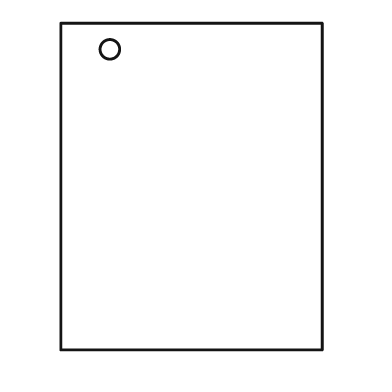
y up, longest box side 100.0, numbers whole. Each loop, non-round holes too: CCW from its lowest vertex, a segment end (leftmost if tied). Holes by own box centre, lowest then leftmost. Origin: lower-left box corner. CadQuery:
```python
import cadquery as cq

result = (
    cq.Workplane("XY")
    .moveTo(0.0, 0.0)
    .lineTo(80.0, 0.0)
    .lineTo(80.0, 100.0)
    .lineTo(0.0, 100.0)
    .close()
    .moveTo(15.0, 92.0)
    .circle(3.0)
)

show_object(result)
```